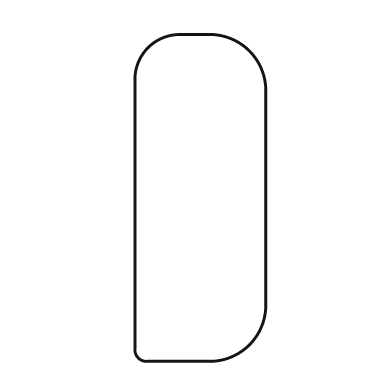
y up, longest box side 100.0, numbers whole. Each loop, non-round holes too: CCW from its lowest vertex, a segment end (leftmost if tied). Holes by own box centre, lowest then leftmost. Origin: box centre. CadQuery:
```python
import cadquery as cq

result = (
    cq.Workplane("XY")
    .moveTo(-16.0, -50.0)
    .lineTo(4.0, -50.0)
    .threePointArc((15.0, -45.0), (20.0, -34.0))
    .lineTo(20.0, 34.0)
    .threePointArc((15.0, 45.0), (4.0, 50.0))
    .lineTo(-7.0, 50.0)
    .threePointArc((-16.0, 46.0), (-20.0, 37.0))
    .lineTo(-20.0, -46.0)
    .threePointArc((-19.0, -49.0), (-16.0, -50.0))
    .close()
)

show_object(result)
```